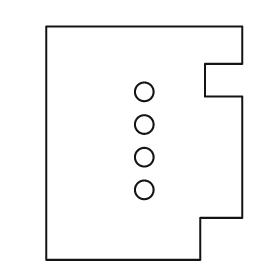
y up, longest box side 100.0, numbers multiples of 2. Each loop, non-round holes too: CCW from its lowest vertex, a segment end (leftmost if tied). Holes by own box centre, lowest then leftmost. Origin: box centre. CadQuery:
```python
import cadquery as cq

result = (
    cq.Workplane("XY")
    .moveTo(-42.0, -50.0)
    .lineTo(24.0, -50.0)
    .lineTo(24.0, -32.0)
    .lineTo(42.0, -32.0)
    .lineTo(42.0, 20.0)
    .lineTo(26.0, 20.0)
    .lineTo(26.0, 34.0)
    .lineTo(42.0, 34.0)
    .lineTo(42.0, 50.0)
    .lineTo(-42.0, 50.0)
    .close()
    .moveTo(0.0, -20.0)
    .circle(4.0)
    .moveTo(0.0, -6.0)
    .circle(4.0)
    .moveTo(0.0, 8.0)
    .circle(4.0)
    .moveTo(0.0, 22.0)
    .circle(4.0)
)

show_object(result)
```